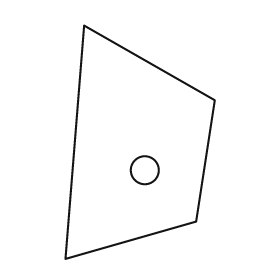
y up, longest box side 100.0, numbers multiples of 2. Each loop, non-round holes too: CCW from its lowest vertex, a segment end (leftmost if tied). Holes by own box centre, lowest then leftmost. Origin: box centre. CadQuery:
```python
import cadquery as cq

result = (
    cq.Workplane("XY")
    .moveTo(-32.0, -50.0)
    .lineTo(24.0, -34.0)
    .lineTo(32.0, 18.0)
    .lineTo(-24.0, 50.0)
    .close()
    .moveTo(2.0, -12.0)
    .circle(6.0)
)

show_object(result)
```